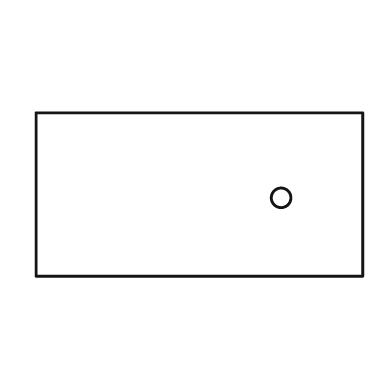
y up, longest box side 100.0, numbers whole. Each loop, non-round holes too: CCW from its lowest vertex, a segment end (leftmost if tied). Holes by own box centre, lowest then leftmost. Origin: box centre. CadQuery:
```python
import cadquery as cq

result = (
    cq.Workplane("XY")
    .moveTo(-50.0, -25.0)
    .lineTo(50.0, -25.0)
    .lineTo(50.0, 25.0)
    .lineTo(-50.0, 25.0)
    .close()
    .moveTo(25.0, -1.0)
    .circle(3.0)
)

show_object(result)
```